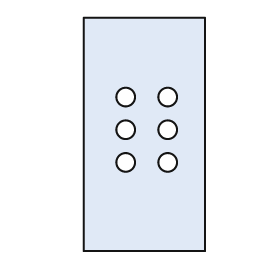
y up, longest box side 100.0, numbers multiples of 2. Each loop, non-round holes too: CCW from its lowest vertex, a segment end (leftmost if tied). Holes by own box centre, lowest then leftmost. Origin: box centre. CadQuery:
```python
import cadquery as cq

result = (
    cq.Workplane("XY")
    .moveTo(-26.0, -50.0)
    .lineTo(26.0, -50.0)
    .lineTo(26.0, 50.0)
    .lineTo(-26.0, 50.0)
    .close()
    .moveTo(-8.0, -12.0)
    .circle(4.0)
    .moveTo(10.0, -12.0)
    .circle(4.0)
    .moveTo(-8.0, 2.0)
    .circle(4.0)
    .moveTo(10.0, 2.0)
    .circle(4.0)
    .moveTo(-8.0, 16.0)
    .circle(4.0)
    .moveTo(10.0, 16.0)
    .circle(4.0)
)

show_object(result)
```